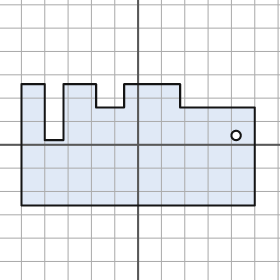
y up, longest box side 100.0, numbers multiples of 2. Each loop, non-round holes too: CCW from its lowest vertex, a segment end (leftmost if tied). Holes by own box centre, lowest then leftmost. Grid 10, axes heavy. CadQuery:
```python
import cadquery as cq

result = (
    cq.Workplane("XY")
    .moveTo(-50.0, -26.0)
    .lineTo(50.0, -26.0)
    .lineTo(50.0, 16.0)
    .lineTo(18.0, 16.0)
    .lineTo(18.0, 26.0)
    .lineTo(-6.0, 26.0)
    .lineTo(-6.0, 16.0)
    .lineTo(-18.0, 16.0)
    .lineTo(-18.0, 26.0)
    .lineTo(-32.0, 26.0)
    .lineTo(-32.0, 2.0)
    .lineTo(-40.0, 2.0)
    .lineTo(-40.0, 26.0)
    .lineTo(-50.0, 26.0)
    .close()
    .moveTo(42.0, 4.0)
    .circle(2.0)
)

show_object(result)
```